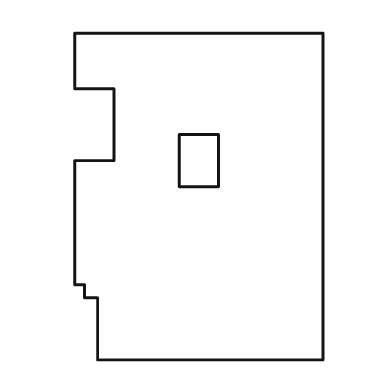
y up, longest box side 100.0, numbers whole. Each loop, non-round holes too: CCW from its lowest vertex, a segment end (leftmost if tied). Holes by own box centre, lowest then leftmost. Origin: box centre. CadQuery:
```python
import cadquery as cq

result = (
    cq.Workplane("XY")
    .moveTo(-31.0, -50.0)
    .lineTo(38.0, -50.0)
    .lineTo(38.0, 50.0)
    .lineTo(-38.0, 50.0)
    .lineTo(-38.0, 33.0)
    .lineTo(-26.0, 33.0)
    .lineTo(-26.0, 11.0)
    .lineTo(-38.0, 11.0)
    .lineTo(-38.0, -27.0)
    .lineTo(-35.0, -27.0)
    .lineTo(-35.0, -31.0)
    .lineTo(-31.0, -31.0)
    .close()
    .moveTo(-6.0, 3.0)
    .lineTo(6.0, 3.0)
    .lineTo(6.0, 19.0)
    .lineTo(-6.0, 19.0)
    .close()
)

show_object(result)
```